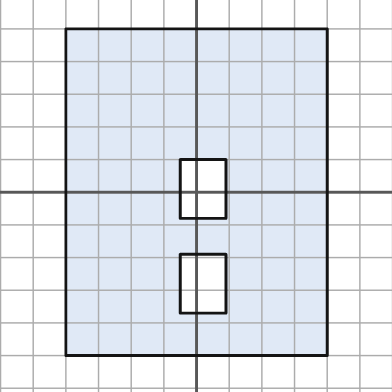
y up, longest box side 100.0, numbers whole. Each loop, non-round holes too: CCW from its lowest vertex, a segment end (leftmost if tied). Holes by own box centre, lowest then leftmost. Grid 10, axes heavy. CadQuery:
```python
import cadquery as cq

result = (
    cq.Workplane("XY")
    .moveTo(-40.0, -50.0)
    .lineTo(40.0, -50.0)
    .lineTo(40.0, 50.0)
    .lineTo(-40.0, 50.0)
    .close()
    .moveTo(-5.0, -37.0)
    .lineTo(9.0, -37.0)
    .lineTo(9.0, -19.0)
    .lineTo(-5.0, -19.0)
    .close()
    .moveTo(-5.0, -8.0)
    .lineTo(9.0, -8.0)
    .lineTo(9.0, 10.0)
    .lineTo(-5.0, 10.0)
    .close()
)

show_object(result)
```